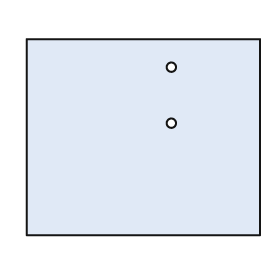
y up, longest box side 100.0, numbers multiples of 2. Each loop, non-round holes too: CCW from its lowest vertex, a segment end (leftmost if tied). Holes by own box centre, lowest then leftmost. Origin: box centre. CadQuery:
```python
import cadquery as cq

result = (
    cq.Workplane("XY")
    .moveTo(-50.0, -42.0)
    .lineTo(50.0, -42.0)
    .lineTo(50.0, 42.0)
    .lineTo(-50.0, 42.0)
    .close()
    .moveTo(12.0, 6.0)
    .circle(2.0)
    .moveTo(12.0, 30.0)
    .circle(2.0)
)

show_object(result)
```